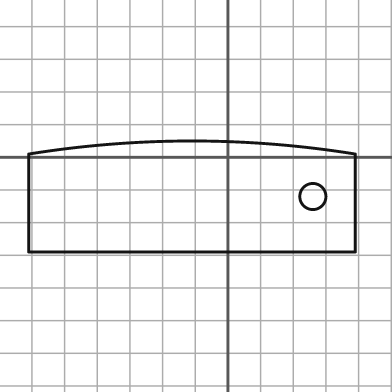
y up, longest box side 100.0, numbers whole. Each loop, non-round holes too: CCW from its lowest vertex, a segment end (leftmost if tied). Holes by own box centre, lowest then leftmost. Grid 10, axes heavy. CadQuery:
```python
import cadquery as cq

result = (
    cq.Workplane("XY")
    .moveTo(-61.0, -29.0)
    .lineTo(39.0, -29.0)
    .lineTo(39.0, 1.0)
    .threePointArc((-11.0, 5.0), (-61.0, 1.0))
    .close()
    .moveTo(26.0, -12.0)
    .circle(4.0)
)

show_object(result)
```